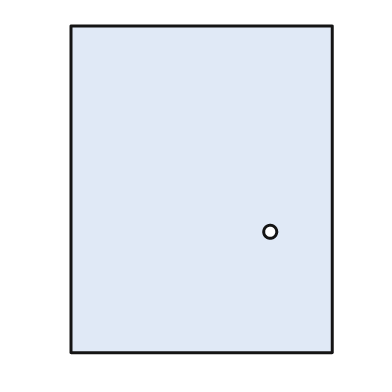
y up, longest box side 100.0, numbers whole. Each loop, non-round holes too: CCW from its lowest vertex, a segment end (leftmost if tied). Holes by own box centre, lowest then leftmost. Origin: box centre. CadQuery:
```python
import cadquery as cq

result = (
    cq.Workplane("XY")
    .moveTo(-40.0, -50.0)
    .lineTo(40.0, -50.0)
    .lineTo(40.0, 50.0)
    .lineTo(-40.0, 50.0)
    .close()
    .moveTo(21.0, -13.0)
    .circle(2.0)
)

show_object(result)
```